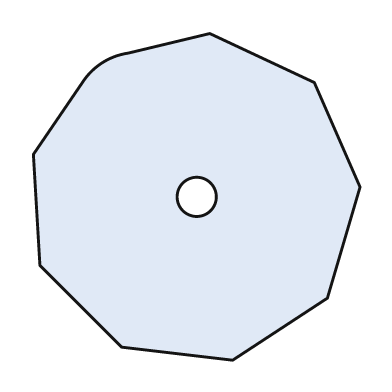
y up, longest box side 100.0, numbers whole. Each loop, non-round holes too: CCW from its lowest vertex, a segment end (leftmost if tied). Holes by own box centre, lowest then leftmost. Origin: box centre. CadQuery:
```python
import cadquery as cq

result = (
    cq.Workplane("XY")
    .moveTo(11.0, -50.0)
    .lineTo(40.0, -31.0)
    .lineTo(50.0, 3.0)
    .lineTo(36.0, 35.0)
    .lineTo(4.0, 50.0)
    .lineTo(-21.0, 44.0)
    .threePointArc((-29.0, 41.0), (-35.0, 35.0))
    .lineTo(-50.0, 13.0)
    .lineTo(-48.0, -21.0)
    .lineTo(-23.0, -46.0)
    .close()
    .moveTo(0.0, 0.0)
    .circle(6.0)
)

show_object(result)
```